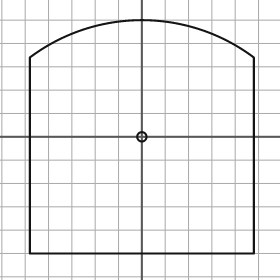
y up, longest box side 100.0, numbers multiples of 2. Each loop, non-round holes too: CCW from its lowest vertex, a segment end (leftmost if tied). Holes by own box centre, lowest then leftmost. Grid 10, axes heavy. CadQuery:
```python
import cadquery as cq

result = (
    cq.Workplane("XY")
    .moveTo(-48.0, -50.0)
    .lineTo(48.0, -50.0)
    .lineTo(48.0, 34.0)
    .threePointArc((0.0, 50.0), (-48.0, 34.0))
    .close()
    .moveTo(0.0, 0.0)
    .circle(2.0)
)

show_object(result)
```